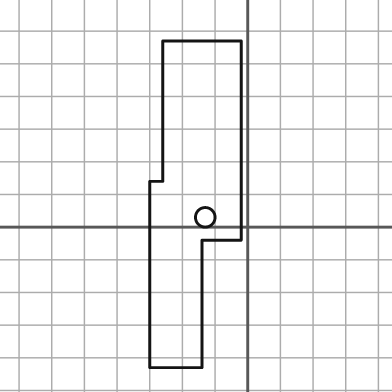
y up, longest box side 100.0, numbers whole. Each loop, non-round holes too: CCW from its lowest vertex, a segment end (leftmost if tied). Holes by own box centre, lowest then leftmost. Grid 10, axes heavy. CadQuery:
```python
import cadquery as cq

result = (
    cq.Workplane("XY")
    .moveTo(-30.0, -43.0)
    .lineTo(-14.0, -43.0)
    .lineTo(-14.0, -4.0)
    .lineTo(-2.0, -4.0)
    .lineTo(-2.0, 57.0)
    .lineTo(-26.0, 57.0)
    .lineTo(-26.0, 14.0)
    .lineTo(-30.0, 14.0)
    .close()
    .moveTo(-13.0, 3.0)
    .circle(3.0)
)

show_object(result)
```